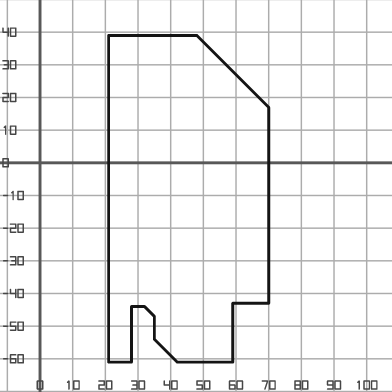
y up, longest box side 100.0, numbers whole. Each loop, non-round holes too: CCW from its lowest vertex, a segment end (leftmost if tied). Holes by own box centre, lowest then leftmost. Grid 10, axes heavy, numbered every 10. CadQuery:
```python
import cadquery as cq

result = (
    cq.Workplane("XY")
    .moveTo(21.0, -61.0)
    .lineTo(28.0, -61.0)
    .lineTo(28.0, -44.0)
    .lineTo(32.0, -44.0)
    .lineTo(35.0, -47.0)
    .lineTo(35.0, -54.0)
    .lineTo(42.0, -61.0)
    .lineTo(59.0, -61.0)
    .lineTo(59.0, -43.0)
    .lineTo(70.0, -43.0)
    .lineTo(70.0, 17.0)
    .lineTo(48.0, 39.0)
    .lineTo(21.0, 39.0)
    .close()
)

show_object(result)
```